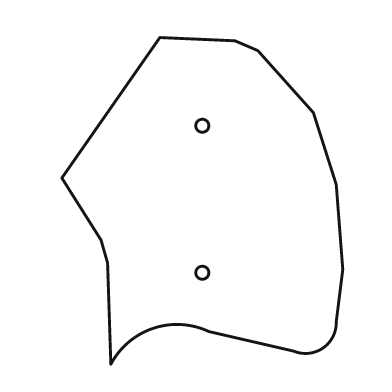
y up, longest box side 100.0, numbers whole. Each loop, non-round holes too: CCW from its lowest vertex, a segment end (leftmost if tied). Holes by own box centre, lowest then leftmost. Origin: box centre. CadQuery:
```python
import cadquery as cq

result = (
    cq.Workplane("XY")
    .moveTo(-28.0, -50.0)
    .threePointArc((-15.0, -39.0), (2.0, -40.0))
    .lineTo(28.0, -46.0)
    .threePointArc((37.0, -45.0), (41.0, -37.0))
    .lineTo(43.0, -21.0)
    .lineTo(41.0, 5.0)
    .lineTo(34.0, 27.0)
    .lineTo(17.0, 46.0)
    .lineTo(10.0, 49.0)
    .lineTo(-13.0, 50.0)
    .lineTo(-43.0, 7.0)
    .lineTo(-31.0, -12.0)
    .lineTo(-29.0, -19.0)
    .close()
    .moveTo(0.0, -22.0)
    .circle(2.0)
    .moveTo(0.0, 23.0)
    .circle(2.0)
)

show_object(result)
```